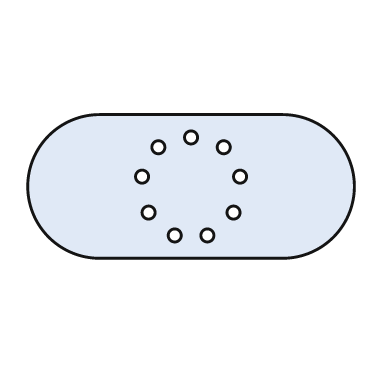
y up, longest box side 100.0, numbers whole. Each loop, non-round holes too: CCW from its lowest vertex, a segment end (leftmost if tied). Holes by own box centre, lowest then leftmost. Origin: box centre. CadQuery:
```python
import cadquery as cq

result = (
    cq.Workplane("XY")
    .moveTo(-28.0, -22.0)
    .lineTo(28.0, -22.0)
    .threePointArc((50.0, 0.0), (28.0, 22.0))
    .lineTo(-28.0, 22.0)
    .threePointArc((-50.0, 0.0), (-28.0, -22.0))
    .close()
    .moveTo(-5.0, -15.0)
    .circle(2.0)
    .moveTo(5.0, -15.0)
    .circle(2.0)
    .moveTo(-13.0, -8.0)
    .circle(2.0)
    .moveTo(13.0, -8.0)
    .circle(2.0)
    .moveTo(-15.0, 3.0)
    .circle(2.0)
    .moveTo(15.0, 3.0)
    .circle(2.0)
    .moveTo(-10.0, 12.0)
    .circle(2.0)
    .moveTo(10.0, 12.0)
    .circle(2.0)
    .moveTo(0.0, 15.0)
    .circle(2.0)
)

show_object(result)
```